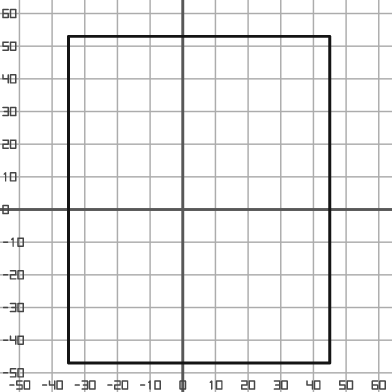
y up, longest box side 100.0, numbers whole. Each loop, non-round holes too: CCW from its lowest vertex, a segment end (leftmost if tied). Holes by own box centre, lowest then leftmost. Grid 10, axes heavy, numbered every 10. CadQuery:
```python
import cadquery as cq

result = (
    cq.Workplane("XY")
    .moveTo(-35.0, -47.0)
    .lineTo(45.0, -47.0)
    .lineTo(45.0, 53.0)
    .lineTo(-35.0, 53.0)
    .close()
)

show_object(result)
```